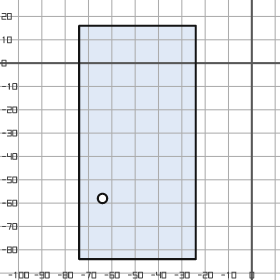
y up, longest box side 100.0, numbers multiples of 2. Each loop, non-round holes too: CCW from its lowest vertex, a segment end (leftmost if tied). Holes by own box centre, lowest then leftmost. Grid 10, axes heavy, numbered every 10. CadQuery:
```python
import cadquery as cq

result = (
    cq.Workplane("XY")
    .moveTo(-74.0, -84.0)
    .lineTo(-24.0, -84.0)
    .lineTo(-24.0, 16.0)
    .lineTo(-74.0, 16.0)
    .close()
    .moveTo(-64.0, -58.0)
    .circle(2.0)
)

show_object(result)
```